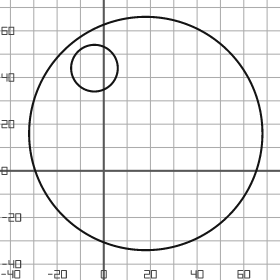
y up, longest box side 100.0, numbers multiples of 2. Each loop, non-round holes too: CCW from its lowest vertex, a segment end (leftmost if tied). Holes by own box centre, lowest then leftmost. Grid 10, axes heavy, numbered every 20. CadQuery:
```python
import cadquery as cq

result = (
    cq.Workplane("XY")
    .moveTo(18.0, 16.0)
    .circle(50.0)
    .moveTo(-4.0, 44.0)
    .circle(10.0)
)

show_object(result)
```